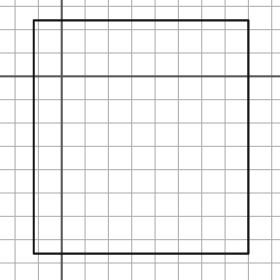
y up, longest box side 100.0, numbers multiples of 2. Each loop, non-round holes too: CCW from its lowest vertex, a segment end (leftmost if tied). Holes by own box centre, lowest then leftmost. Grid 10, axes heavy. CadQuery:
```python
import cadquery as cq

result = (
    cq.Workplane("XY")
    .moveTo(-12.0, -76.0)
    .lineTo(80.0, -76.0)
    .lineTo(80.0, 24.0)
    .lineTo(-12.0, 24.0)
    .close()
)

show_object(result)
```